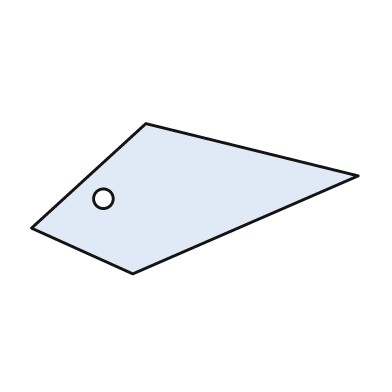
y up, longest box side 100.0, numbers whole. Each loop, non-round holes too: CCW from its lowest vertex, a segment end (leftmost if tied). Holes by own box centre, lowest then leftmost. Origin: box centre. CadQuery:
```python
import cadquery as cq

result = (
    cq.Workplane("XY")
    .moveTo(-19.0, -23.0)
    .lineTo(50.0, 7.0)
    .lineTo(-15.0, 23.0)
    .lineTo(-50.0, -9.0)
    .close()
    .moveTo(-28.0, 0.0)
    .circle(3.0)
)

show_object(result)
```